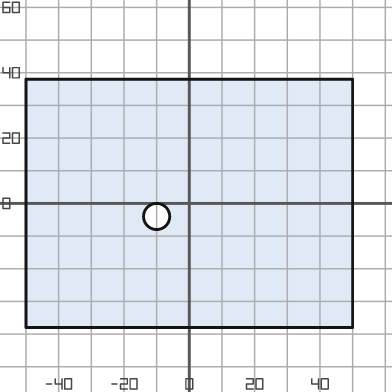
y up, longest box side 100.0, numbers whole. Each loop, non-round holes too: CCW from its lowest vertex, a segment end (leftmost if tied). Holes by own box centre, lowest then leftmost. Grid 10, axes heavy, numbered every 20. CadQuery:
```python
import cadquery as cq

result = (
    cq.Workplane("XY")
    .moveTo(-50.0, -38.0)
    .lineTo(50.0, -38.0)
    .lineTo(50.0, 38.0)
    .lineTo(-50.0, 38.0)
    .close()
    .moveTo(-10.0, -4.0)
    .circle(4.0)
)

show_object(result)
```